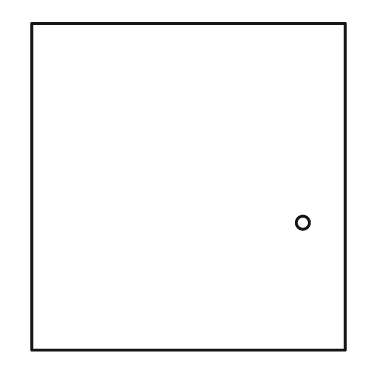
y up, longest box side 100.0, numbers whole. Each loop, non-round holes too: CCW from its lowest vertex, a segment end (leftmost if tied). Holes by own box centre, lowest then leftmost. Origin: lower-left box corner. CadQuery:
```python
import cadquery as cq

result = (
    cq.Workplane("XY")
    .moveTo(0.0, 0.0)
    .lineTo(96.0, 0.0)
    .lineTo(96.0, 100.0)
    .lineTo(0.0, 100.0)
    .close()
    .moveTo(83.0, 39.0)
    .circle(2.0)
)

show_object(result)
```